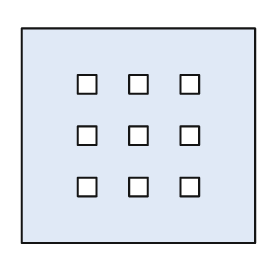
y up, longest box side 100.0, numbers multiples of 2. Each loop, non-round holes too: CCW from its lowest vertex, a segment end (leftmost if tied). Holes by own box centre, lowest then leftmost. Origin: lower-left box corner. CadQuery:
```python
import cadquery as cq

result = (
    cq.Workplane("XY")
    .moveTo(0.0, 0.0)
    .lineTo(100.0, 0.0)
    .lineTo(100.0, 92.0)
    .lineTo(0.0, 92.0)
    .close()
    .moveTo(24.0, 20.0)
    .lineTo(32.0, 20.0)
    .lineTo(32.0, 28.0)
    .lineTo(24.0, 28.0)
    .close()
    .moveTo(46.0, 20.0)
    .lineTo(54.0, 20.0)
    .lineTo(54.0, 28.0)
    .lineTo(46.0, 28.0)
    .close()
    .moveTo(68.0, 20.0)
    .lineTo(76.0, 20.0)
    .lineTo(76.0, 28.0)
    .lineTo(68.0, 28.0)
    .close()
    .moveTo(24.0, 42.0)
    .lineTo(32.0, 42.0)
    .lineTo(32.0, 50.0)
    .lineTo(24.0, 50.0)
    .close()
    .moveTo(46.0, 42.0)
    .lineTo(54.0, 42.0)
    .lineTo(54.0, 50.0)
    .lineTo(46.0, 50.0)
    .close()
    .moveTo(68.0, 42.0)
    .lineTo(76.0, 42.0)
    .lineTo(76.0, 50.0)
    .lineTo(68.0, 50.0)
    .close()
    .moveTo(24.0, 64.0)
    .lineTo(32.0, 64.0)
    .lineTo(32.0, 72.0)
    .lineTo(24.0, 72.0)
    .close()
    .moveTo(46.0, 64.0)
    .lineTo(54.0, 64.0)
    .lineTo(54.0, 72.0)
    .lineTo(46.0, 72.0)
    .close()
    .moveTo(68.0, 64.0)
    .lineTo(76.0, 64.0)
    .lineTo(76.0, 72.0)
    .lineTo(68.0, 72.0)
    .close()
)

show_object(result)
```